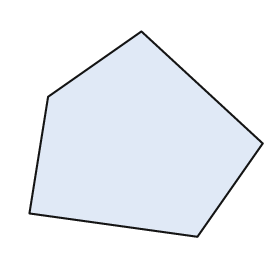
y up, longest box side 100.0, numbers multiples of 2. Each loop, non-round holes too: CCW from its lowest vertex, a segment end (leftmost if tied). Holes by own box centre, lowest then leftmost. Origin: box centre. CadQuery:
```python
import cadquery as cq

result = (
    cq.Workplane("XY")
    .moveTo(22.0, -44.0)
    .lineTo(50.0, -4.0)
    .lineTo(-2.0, 44.0)
    .lineTo(-42.0, 16.0)
    .lineTo(-50.0, -34.0)
    .close()
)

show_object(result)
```